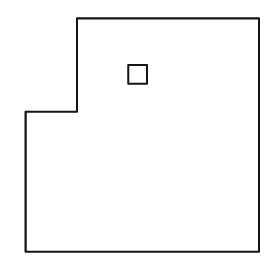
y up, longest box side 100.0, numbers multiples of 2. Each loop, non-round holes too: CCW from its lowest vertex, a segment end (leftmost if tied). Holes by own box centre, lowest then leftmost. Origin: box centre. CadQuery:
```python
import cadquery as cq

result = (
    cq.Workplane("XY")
    .moveTo(-50.0, -50.0)
    .lineTo(50.0, -50.0)
    .lineTo(50.0, 50.0)
    .lineTo(-28.0, 50.0)
    .lineTo(-28.0, 10.0)
    .lineTo(-50.0, 10.0)
    .close()
    .moveTo(-6.0, 22.0)
    .lineTo(2.0, 22.0)
    .lineTo(2.0, 30.0)
    .lineTo(-6.0, 30.0)
    .close()
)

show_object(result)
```